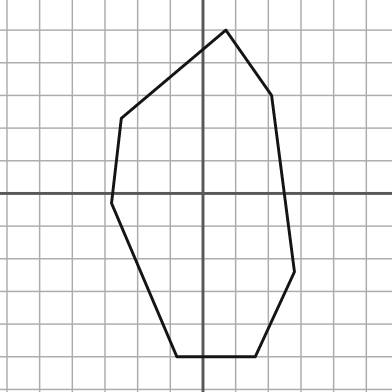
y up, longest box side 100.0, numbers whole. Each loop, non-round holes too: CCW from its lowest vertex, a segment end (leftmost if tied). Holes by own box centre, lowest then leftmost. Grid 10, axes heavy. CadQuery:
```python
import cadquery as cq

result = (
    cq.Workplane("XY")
    .moveTo(-8.0, -50.0)
    .lineTo(16.0, -50.0)
    .lineTo(28.0, -24.0)
    .lineTo(21.0, 30.0)
    .lineTo(7.0, 50.0)
    .lineTo(-25.0, 23.0)
    .lineTo(-28.0, -3.0)
    .close()
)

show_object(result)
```